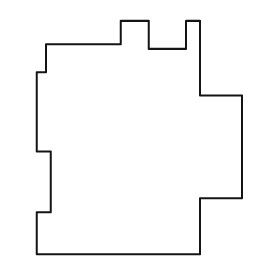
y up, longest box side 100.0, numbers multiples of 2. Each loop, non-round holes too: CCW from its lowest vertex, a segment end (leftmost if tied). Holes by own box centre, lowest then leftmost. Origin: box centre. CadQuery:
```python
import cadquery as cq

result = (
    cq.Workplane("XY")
    .moveTo(-44.0, -50.0)
    .lineTo(26.0, -50.0)
    .lineTo(26.0, -26.0)
    .lineTo(44.0, -26.0)
    .lineTo(44.0, 18.0)
    .lineTo(26.0, 18.0)
    .lineTo(26.0, 50.0)
    .lineTo(20.0, 50.0)
    .lineTo(20.0, 38.0)
    .lineTo(4.0, 38.0)
    .lineTo(4.0, 50.0)
    .lineTo(-8.0, 50.0)
    .lineTo(-8.0, 40.0)
    .lineTo(-40.0, 40.0)
    .lineTo(-40.0, 28.0)
    .lineTo(-44.0, 28.0)
    .lineTo(-44.0, -6.0)
    .lineTo(-38.0, -6.0)
    .lineTo(-38.0, -32.0)
    .lineTo(-44.0, -32.0)
    .close()
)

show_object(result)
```